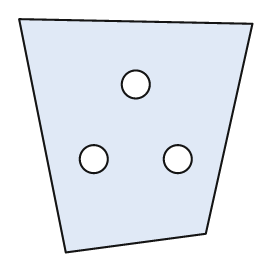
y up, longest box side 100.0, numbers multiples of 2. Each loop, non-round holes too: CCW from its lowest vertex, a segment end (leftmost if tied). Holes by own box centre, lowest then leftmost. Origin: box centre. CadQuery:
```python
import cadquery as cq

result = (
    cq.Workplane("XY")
    .moveTo(-30.0, -50.0)
    .lineTo(30.0, -42.0)
    .lineTo(50.0, 48.0)
    .lineTo(-50.0, 50.0)
    .close()
    .moveTo(-18.0, -10.0)
    .circle(6.0)
    .moveTo(18.0, -10.0)
    .circle(6.0)
    .moveTo(0.0, 22.0)
    .circle(6.0)
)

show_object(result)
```